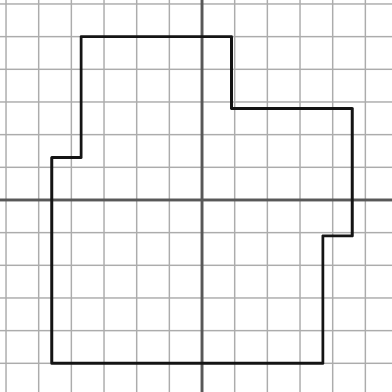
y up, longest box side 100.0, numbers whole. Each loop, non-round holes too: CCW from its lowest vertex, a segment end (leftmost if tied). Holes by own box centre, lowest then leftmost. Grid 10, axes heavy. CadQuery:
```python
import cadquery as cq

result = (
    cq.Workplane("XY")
    .moveTo(-46.0, -50.0)
    .lineTo(37.0, -50.0)
    .lineTo(37.0, -11.0)
    .lineTo(46.0, -11.0)
    .lineTo(46.0, 28.0)
    .lineTo(9.0, 28.0)
    .lineTo(9.0, 50.0)
    .lineTo(-37.0, 50.0)
    .lineTo(-37.0, 13.0)
    .lineTo(-46.0, 13.0)
    .close()
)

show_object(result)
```